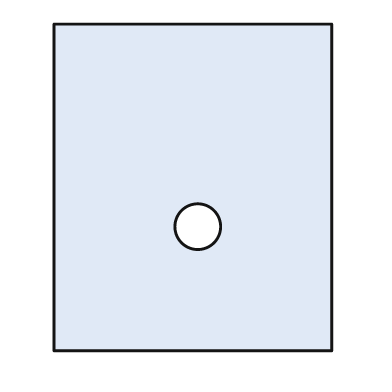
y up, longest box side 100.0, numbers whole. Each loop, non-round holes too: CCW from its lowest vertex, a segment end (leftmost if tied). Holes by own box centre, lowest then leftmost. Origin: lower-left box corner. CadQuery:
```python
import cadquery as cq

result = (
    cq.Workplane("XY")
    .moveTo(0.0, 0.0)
    .lineTo(85.0, 0.0)
    .lineTo(85.0, 100.0)
    .lineTo(0.0, 100.0)
    .close()
    .moveTo(44.0, 38.0)
    .circle(7.0)
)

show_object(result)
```